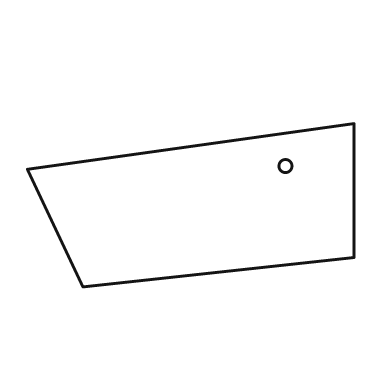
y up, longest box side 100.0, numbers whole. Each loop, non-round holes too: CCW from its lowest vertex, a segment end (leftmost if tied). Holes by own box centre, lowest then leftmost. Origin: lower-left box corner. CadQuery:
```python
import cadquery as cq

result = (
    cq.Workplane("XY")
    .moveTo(17.0, 0.0)
    .lineTo(100.0, 9.0)
    .lineTo(100.0, 50.0)
    .lineTo(0.0, 36.0)
    .close()
    .moveTo(79.0, 37.0)
    .circle(2.0)
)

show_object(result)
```